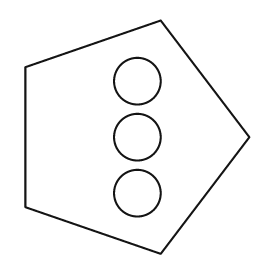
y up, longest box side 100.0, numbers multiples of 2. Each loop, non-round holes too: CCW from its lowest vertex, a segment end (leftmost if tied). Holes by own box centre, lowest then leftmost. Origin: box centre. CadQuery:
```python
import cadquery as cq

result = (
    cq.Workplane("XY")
    .moveTo(10.0, -50.0)
    .lineTo(48.0, 0.0)
    .lineTo(10.0, 50.0)
    .lineTo(-48.0, 30.0)
    .lineTo(-48.0, -30.0)
    .close()
    .moveTo(0.0, -24.0)
    .circle(10.0)
    .moveTo(0.0, 0.0)
    .circle(10.0)
    .moveTo(0.0, 24.0)
    .circle(10.0)
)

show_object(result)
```